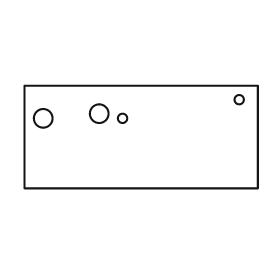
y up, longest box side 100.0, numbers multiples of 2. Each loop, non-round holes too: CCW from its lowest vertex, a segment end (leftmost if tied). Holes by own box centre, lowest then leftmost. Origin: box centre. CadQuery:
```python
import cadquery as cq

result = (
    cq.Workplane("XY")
    .moveTo(-50.0, -22.0)
    .lineTo(50.0, -22.0)
    .lineTo(50.0, 22.0)
    .lineTo(-50.0, 22.0)
    .close()
    .moveTo(-42.0, 8.0)
    .circle(4.0)
    .moveTo(-8.0, 8.0)
    .circle(2.0)
    .moveTo(-18.0, 10.0)
    .circle(4.0)
    .moveTo(42.0, 16.0)
    .circle(2.0)
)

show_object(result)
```